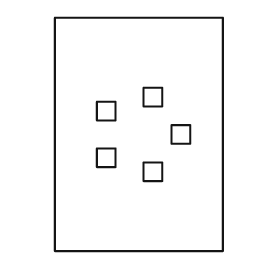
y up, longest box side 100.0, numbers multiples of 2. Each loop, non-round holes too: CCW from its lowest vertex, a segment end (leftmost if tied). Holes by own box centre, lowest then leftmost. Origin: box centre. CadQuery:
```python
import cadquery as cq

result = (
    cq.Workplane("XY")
    .moveTo(-36.0, -50.0)
    .lineTo(36.0, -50.0)
    .lineTo(36.0, 50.0)
    .lineTo(-36.0, 50.0)
    .close()
    .moveTo(2.0, -20.0)
    .lineTo(10.0, -20.0)
    .lineTo(10.0, -12.0)
    .lineTo(2.0, -12.0)
    .close()
    .moveTo(-18.0, -14.0)
    .lineTo(-10.0, -14.0)
    .lineTo(-10.0, -6.0)
    .lineTo(-18.0, -6.0)
    .close()
    .moveTo(14.0, -4.0)
    .lineTo(22.0, -4.0)
    .lineTo(22.0, 4.0)
    .lineTo(14.0, 4.0)
    .close()
    .moveTo(-18.0, 6.0)
    .lineTo(-10.0, 6.0)
    .lineTo(-10.0, 14.0)
    .lineTo(-18.0, 14.0)
    .close()
    .moveTo(2.0, 12.0)
    .lineTo(10.0, 12.0)
    .lineTo(10.0, 20.0)
    .lineTo(2.0, 20.0)
    .close()
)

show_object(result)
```